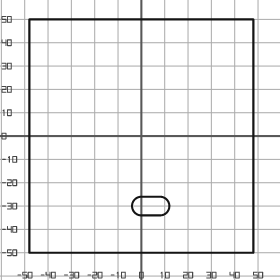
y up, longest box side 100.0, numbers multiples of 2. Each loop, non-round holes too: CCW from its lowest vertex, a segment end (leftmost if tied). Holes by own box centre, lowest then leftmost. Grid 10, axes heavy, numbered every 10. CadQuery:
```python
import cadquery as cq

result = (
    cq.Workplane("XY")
    .moveTo(-48.0, -50.0)
    .lineTo(48.0, -50.0)
    .lineTo(48.0, 50.0)
    .lineTo(-48.0, 50.0)
    .close()
    .moveTo(0.0, -34.0)
    .lineTo(8.0, -34.0)
    .threePointArc((12.0, -30.0), (8.0, -26.0))
    .lineTo(0.0, -26.0)
    .threePointArc((-4.0, -30.0), (0.0, -34.0))
    .close()
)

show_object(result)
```